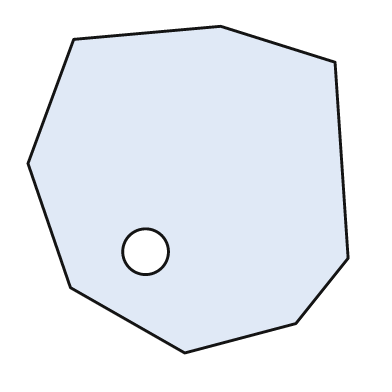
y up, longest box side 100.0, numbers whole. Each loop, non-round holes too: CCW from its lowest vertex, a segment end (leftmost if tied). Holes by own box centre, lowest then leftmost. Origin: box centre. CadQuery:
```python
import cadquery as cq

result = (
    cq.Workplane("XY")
    .moveTo(-1.0, -50.0)
    .lineTo(33.0, -41.0)
    .lineTo(49.0, -21.0)
    .lineTo(45.0, 39.0)
    .lineTo(10.0, 50.0)
    .lineTo(-35.0, 46.0)
    .lineTo(-49.0, 8.0)
    .lineTo(-36.0, -30.0)
    .close()
    .moveTo(-13.0, -19.0)
    .circle(7.0)
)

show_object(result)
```